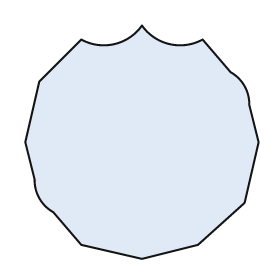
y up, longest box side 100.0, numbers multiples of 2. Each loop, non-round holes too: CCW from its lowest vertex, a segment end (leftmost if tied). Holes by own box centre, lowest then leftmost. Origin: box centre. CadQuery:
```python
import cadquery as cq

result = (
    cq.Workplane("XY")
    .moveTo(0.0, -50.0)
    .lineTo(24.0, -44.0)
    .lineTo(44.0, -26.0)
    .lineTo(50.0, 0.0)
    .lineTo(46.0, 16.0)
    .threePointArc((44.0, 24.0), (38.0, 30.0))
    .lineTo(26.0, 44.0)
    .threePointArc((12.0, 42.0), (0.0, 50.0))
    .threePointArc((-12.0, 42.0), (-26.0, 44.0))
    .lineTo(-44.0, 26.0)
    .lineTo(-50.0, 0.0)
    .lineTo(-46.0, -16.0)
    .threePointArc((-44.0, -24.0), (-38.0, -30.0))
    .lineTo(-26.0, -44.0)
    .close()
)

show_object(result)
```